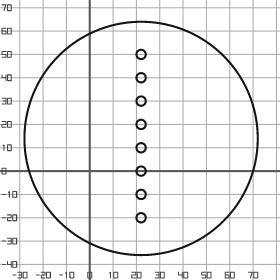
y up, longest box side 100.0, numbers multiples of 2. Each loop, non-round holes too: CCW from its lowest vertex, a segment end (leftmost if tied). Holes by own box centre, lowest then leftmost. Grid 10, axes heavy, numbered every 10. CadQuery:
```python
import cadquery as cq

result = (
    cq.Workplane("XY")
    .moveTo(22.0, 14.0)
    .circle(50.0)
    .moveTo(22.0, -20.0)
    .circle(2.0)
    .moveTo(22.0, -10.0)
    .circle(2.0)
    .moveTo(22.0, 0.0)
    .circle(2.0)
    .moveTo(22.0, 10.0)
    .circle(2.0)
    .moveTo(22.0, 20.0)
    .circle(2.0)
    .moveTo(22.0, 30.0)
    .circle(2.0)
    .moveTo(22.0, 40.0)
    .circle(2.0)
    .moveTo(22.0, 50.0)
    .circle(2.0)
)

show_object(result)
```